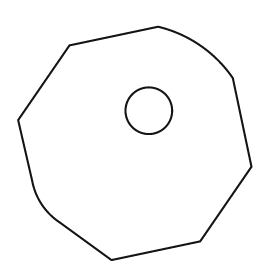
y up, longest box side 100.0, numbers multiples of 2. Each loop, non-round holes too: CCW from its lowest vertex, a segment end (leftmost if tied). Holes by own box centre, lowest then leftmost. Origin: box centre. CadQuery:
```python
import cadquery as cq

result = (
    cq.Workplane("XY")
    .moveTo(-10.0, -50.0)
    .lineTo(28.0, -42.0)
    .lineTo(50.0, -10.0)
    .lineTo(42.0, 28.0)
    .threePointArc((28.0, 42.0), (10.0, 50.0))
    .lineTo(-28.0, 42.0)
    .lineTo(-50.0, 10.0)
    .lineTo(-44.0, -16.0)
    .threePointArc((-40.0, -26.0), (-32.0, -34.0))
    .close()
    .moveTo(6.0, 14.0)
    .circle(10.0)
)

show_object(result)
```